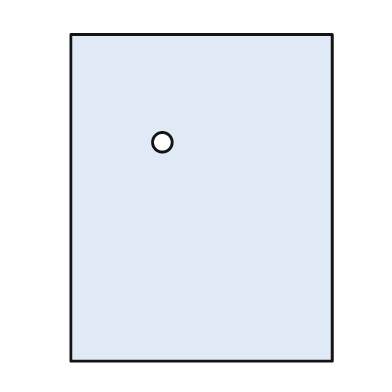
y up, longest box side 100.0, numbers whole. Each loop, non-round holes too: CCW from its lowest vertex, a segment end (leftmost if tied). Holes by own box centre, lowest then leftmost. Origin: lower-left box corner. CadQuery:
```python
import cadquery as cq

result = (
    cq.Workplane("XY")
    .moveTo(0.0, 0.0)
    .lineTo(80.0, 0.0)
    .lineTo(80.0, 100.0)
    .lineTo(0.0, 100.0)
    .close()
    .moveTo(28.0, 67.0)
    .circle(3.0)
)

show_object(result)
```